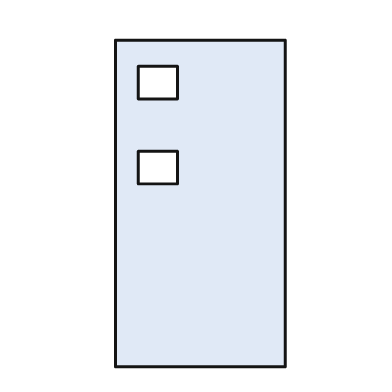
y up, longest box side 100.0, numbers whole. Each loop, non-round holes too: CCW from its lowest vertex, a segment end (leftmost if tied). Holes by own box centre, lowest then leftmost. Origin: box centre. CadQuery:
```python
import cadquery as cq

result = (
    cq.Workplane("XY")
    .moveTo(-26.0, -50.0)
    .lineTo(26.0, -50.0)
    .lineTo(26.0, 50.0)
    .lineTo(-26.0, 50.0)
    .close()
    .moveTo(-19.0, 6.0)
    .lineTo(-7.0, 6.0)
    .lineTo(-7.0, 16.0)
    .lineTo(-19.0, 16.0)
    .close()
    .moveTo(-19.0, 32.0)
    .lineTo(-7.0, 32.0)
    .lineTo(-7.0, 42.0)
    .lineTo(-19.0, 42.0)
    .close()
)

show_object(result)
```